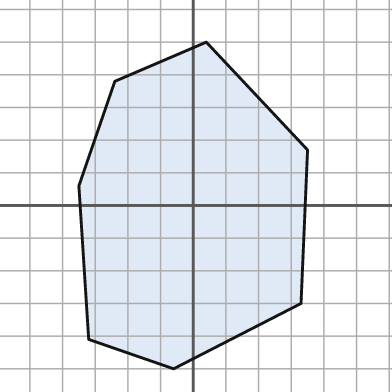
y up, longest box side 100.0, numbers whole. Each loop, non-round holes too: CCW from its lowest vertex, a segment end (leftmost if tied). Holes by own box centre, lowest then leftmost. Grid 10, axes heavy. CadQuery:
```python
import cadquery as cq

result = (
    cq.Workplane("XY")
    .moveTo(-6.0, -50.0)
    .lineTo(33.0, -30.0)
    .lineTo(35.0, 17.0)
    .lineTo(4.0, 50.0)
    .lineTo(-24.0, 38.0)
    .lineTo(-35.0, 6.0)
    .lineTo(-32.0, -41.0)
    .close()
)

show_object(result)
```